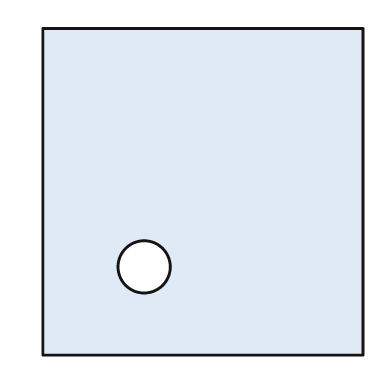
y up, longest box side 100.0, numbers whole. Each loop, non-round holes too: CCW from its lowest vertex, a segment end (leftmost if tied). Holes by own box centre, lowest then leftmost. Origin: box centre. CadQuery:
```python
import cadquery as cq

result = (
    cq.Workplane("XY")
    .moveTo(-49.0, -50.0)
    .lineTo(49.0, -50.0)
    .lineTo(49.0, 50.0)
    .lineTo(-49.0, 50.0)
    .close()
    .moveTo(-18.0, -23.0)
    .circle(8.0)
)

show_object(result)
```